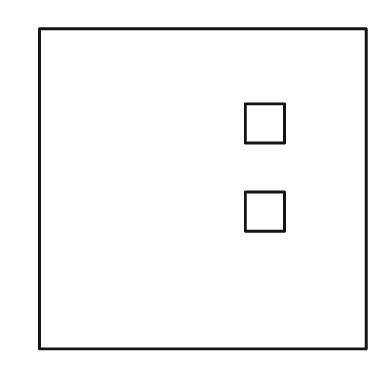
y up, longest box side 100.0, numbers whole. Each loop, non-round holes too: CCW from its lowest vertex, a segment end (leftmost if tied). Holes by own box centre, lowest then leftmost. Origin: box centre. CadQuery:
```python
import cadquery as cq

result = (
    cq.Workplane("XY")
    .moveTo(-50.0, -49.0)
    .lineTo(50.0, -49.0)
    .lineTo(50.0, 49.0)
    .lineTo(-50.0, 49.0)
    .close()
    .moveTo(13.0, -13.0)
    .lineTo(25.0, -13.0)
    .lineTo(25.0, -1.0)
    .lineTo(13.0, -1.0)
    .close()
    .moveTo(13.0, 14.0)
    .lineTo(25.0, 14.0)
    .lineTo(25.0, 26.0)
    .lineTo(13.0, 26.0)
    .close()
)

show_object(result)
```